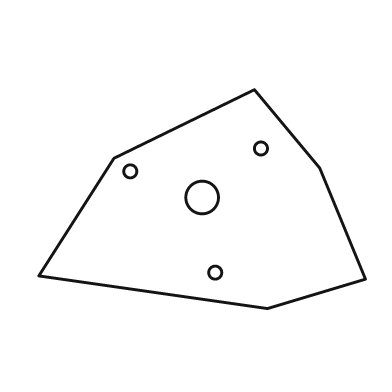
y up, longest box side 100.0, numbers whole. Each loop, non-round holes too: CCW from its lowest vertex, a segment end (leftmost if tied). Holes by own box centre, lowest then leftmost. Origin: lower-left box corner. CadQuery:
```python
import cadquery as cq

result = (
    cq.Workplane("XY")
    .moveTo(70.0, 0.0)
    .lineTo(100.0, 9.0)
    .lineTo(86.0, 43.0)
    .lineTo(66.0, 67.0)
    .lineTo(23.0, 46.0)
    .lineTo(0.0, 10.0)
    .close()
    .moveTo(54.0, 11.0)
    .circle(2.0)
    .moveTo(50.0, 34.0)
    .circle(5.0)
    .moveTo(28.0, 42.0)
    .circle(2.0)
    .moveTo(68.0, 49.0)
    .circle(2.0)
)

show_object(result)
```